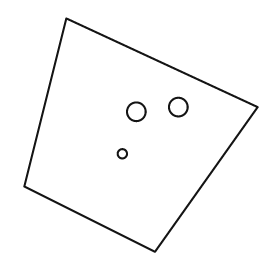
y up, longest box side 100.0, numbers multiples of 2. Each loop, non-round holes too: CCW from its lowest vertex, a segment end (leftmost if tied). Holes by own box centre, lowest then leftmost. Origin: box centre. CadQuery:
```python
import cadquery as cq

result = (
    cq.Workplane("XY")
    .moveTo(6.0, -50.0)
    .lineTo(50.0, 12.0)
    .lineTo(-32.0, 50.0)
    .lineTo(-50.0, -22.0)
    .close()
    .moveTo(-8.0, -8.0)
    .circle(2.0)
    .moveTo(-2.0, 10.0)
    .circle(4.0)
    .moveTo(16.0, 12.0)
    .circle(4.0)
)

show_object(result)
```